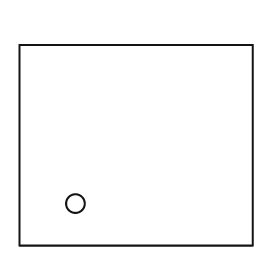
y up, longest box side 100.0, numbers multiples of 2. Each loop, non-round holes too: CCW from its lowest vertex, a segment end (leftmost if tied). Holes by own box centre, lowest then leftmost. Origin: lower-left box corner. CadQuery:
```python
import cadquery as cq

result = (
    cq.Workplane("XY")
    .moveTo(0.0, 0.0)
    .lineTo(100.0, 0.0)
    .lineTo(100.0, 86.0)
    .lineTo(0.0, 86.0)
    .close()
    .moveTo(24.0, 18.0)
    .circle(4.0)
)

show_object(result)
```